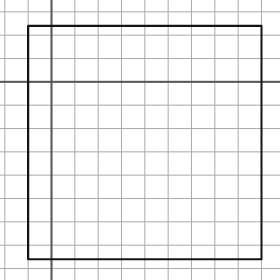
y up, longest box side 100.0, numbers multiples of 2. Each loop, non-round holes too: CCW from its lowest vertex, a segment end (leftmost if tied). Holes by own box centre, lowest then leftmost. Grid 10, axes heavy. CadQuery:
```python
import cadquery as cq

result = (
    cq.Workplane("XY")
    .moveTo(-10.0, -76.0)
    .lineTo(90.0, -76.0)
    .lineTo(90.0, 24.0)
    .lineTo(-10.0, 24.0)
    .close()
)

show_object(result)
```